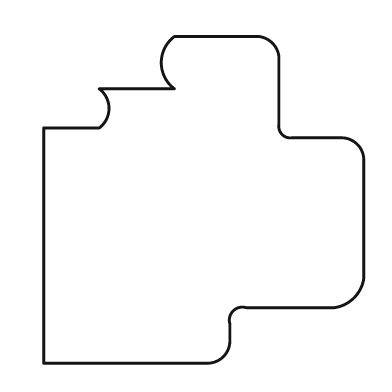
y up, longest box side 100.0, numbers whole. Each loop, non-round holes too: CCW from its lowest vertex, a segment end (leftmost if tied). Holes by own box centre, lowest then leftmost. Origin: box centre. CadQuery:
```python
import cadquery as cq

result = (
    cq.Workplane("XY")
    .moveTo(-49.0, -50.0)
    .lineTo(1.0, -50.0)
    .threePointArc((6.0, -48.0), (8.0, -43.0))
    .lineTo(8.0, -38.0)
    .threePointArc((9.0, -34.0), (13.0, -33.0))
    .lineTo(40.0, -33.0)
    .threePointArc((46.0, -30.0), (49.0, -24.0))
    .lineTo(49.0, 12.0)
    .threePointArc((47.0, 17.0), (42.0, 19.0))
    .lineTo(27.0, 19.0)
    .threePointArc((24.0, 20.0), (23.0, 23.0))
    .lineTo(23.0, 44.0)
    .threePointArc((21.0, 48.0), (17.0, 50.0))
    .lineTo(-9.0, 50.0)
    .threePointArc((-13.0, 42.0), (-9.0, 34.0))
    .lineTo(-32.0, 34.0)
    .threePointArc((-29.0, 28.0), (-32.0, 22.0))
    .lineTo(-49.0, 22.0)
    .close()
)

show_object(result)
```